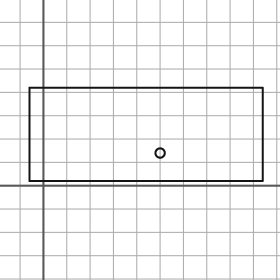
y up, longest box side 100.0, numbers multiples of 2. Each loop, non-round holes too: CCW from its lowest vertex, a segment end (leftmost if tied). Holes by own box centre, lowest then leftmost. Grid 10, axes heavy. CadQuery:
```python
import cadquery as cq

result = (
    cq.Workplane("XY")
    .moveTo(-6.0, 2.0)
    .lineTo(94.0, 2.0)
    .lineTo(94.0, 42.0)
    .lineTo(-6.0, 42.0)
    .close()
    .moveTo(50.0, 14.0)
    .circle(2.0)
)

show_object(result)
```